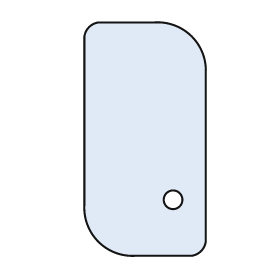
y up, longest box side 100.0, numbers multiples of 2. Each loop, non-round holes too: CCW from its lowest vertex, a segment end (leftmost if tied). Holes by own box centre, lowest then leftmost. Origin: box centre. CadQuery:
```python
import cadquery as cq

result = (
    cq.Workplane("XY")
    .moveTo(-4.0, -50.0)
    .lineTo(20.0, -50.0)
    .threePointArc((24.0, -48.0), (26.0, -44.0))
    .lineTo(26.0, 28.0)
    .threePointArc((20.0, 44.0), (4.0, 50.0))
    .lineTo(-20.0, 50.0)
    .threePointArc((-24.0, 48.0), (-26.0, 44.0))
    .lineTo(-26.0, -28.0)
    .threePointArc((-20.0, -44.0), (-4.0, -50.0))
    .close()
    .moveTo(12.0, -26.0)
    .circle(4.0)
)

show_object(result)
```